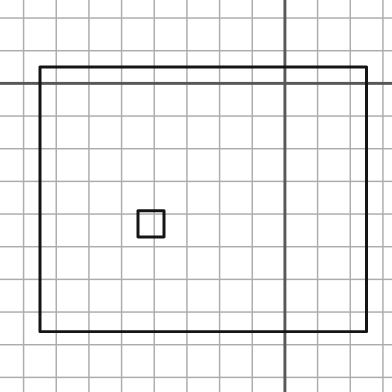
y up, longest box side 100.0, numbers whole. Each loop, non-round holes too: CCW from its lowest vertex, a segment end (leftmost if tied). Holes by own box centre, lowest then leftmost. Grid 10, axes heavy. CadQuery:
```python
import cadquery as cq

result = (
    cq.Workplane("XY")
    .moveTo(-75.0, -76.0)
    .lineTo(25.0, -76.0)
    .lineTo(25.0, 5.0)
    .lineTo(-75.0, 5.0)
    .close()
    .moveTo(-45.0, -47.0)
    .lineTo(-37.0, -47.0)
    .lineTo(-37.0, -39.0)
    .lineTo(-45.0, -39.0)
    .close()
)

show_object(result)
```